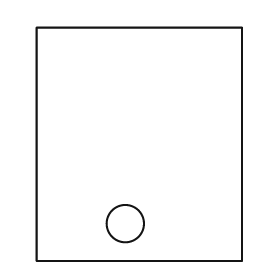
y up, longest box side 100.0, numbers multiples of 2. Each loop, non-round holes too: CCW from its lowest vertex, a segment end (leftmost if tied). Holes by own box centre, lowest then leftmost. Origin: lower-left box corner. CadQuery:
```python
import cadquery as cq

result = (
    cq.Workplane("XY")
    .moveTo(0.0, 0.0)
    .lineTo(88.0, 0.0)
    .lineTo(88.0, 100.0)
    .lineTo(0.0, 100.0)
    .close()
    .moveTo(38.0, 16.0)
    .circle(8.0)
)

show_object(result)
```